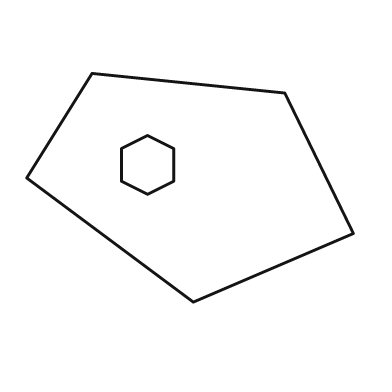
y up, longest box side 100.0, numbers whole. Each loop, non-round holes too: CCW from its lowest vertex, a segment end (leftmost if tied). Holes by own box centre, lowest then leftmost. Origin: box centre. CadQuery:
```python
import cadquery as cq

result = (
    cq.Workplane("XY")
    .moveTo(1.0, -35.0)
    .lineTo(50.0, -14.0)
    .lineTo(29.0, 29.0)
    .lineTo(-30.0, 35.0)
    .lineTo(-50.0, 3.0)
    .close()
    .moveTo(-13.0, -2.0)
    .lineTo(-5.0, 2.0)
    .lineTo(-5.0, 12.0)
    .lineTo(-13.0, 16.0)
    .lineTo(-21.0, 12.0)
    .lineTo(-21.0, 2.0)
    .close()
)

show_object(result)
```